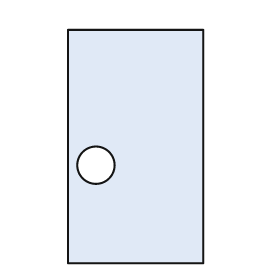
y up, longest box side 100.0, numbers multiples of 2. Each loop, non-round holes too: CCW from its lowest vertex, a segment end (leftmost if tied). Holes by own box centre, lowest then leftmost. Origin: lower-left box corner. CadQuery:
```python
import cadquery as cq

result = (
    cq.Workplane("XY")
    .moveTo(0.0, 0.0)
    .lineTo(58.0, 0.0)
    .lineTo(58.0, 100.0)
    .lineTo(0.0, 100.0)
    .close()
    .moveTo(12.0, 42.0)
    .circle(8.0)
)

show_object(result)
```